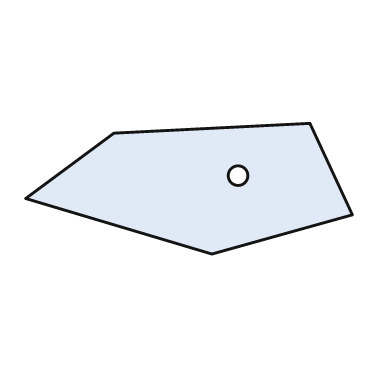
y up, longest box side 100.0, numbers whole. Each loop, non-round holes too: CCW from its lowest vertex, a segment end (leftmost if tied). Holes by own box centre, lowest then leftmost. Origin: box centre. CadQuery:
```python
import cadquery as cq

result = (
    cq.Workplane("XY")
    .moveTo(7.0, -20.0)
    .lineTo(50.0, -8.0)
    .lineTo(37.0, 20.0)
    .lineTo(-23.0, 17.0)
    .lineTo(-50.0, -3.0)
    .close()
    .moveTo(15.0, 4.0)
    .circle(3.0)
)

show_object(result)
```